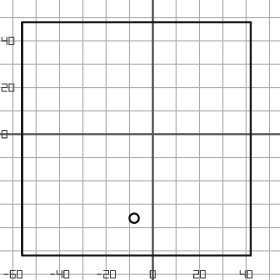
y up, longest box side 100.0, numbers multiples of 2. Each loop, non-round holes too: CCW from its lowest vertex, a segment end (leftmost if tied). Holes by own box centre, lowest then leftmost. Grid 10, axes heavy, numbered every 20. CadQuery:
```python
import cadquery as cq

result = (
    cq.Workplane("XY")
    .moveTo(-56.0, -52.0)
    .lineTo(42.0, -52.0)
    .lineTo(42.0, 48.0)
    .lineTo(-56.0, 48.0)
    .close()
    .moveTo(-8.0, -36.0)
    .circle(2.0)
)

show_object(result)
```